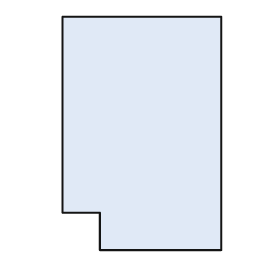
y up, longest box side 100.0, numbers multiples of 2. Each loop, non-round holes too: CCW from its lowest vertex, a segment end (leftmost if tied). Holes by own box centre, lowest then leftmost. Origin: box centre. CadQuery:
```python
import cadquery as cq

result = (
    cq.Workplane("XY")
    .moveTo(-18.0, -50.0)
    .lineTo(34.0, -50.0)
    .lineTo(34.0, 50.0)
    .lineTo(-34.0, 50.0)
    .lineTo(-34.0, -34.0)
    .lineTo(-18.0, -34.0)
    .close()
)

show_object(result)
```